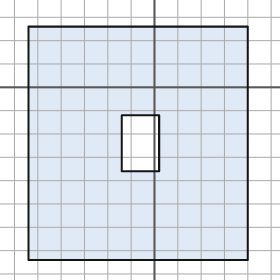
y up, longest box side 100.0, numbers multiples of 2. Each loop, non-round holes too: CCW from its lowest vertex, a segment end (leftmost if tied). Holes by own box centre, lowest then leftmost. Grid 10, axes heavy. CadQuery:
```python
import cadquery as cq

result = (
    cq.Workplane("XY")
    .moveTo(-54.0, -74.0)
    .lineTo(40.0, -74.0)
    .lineTo(40.0, 26.0)
    .lineTo(-54.0, 26.0)
    .close()
    .moveTo(-14.0, -36.0)
    .lineTo(2.0, -36.0)
    .lineTo(2.0, -12.0)
    .lineTo(-14.0, -12.0)
    .close()
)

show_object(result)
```